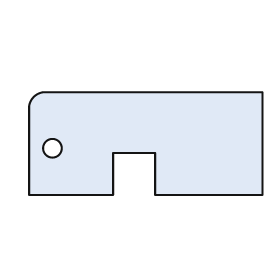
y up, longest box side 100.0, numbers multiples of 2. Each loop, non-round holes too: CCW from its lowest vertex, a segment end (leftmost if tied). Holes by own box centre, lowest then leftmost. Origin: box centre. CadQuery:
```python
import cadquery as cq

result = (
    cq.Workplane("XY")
    .moveTo(-50.0, -22.0)
    .lineTo(-14.0, -22.0)
    .lineTo(-14.0, -4.0)
    .lineTo(4.0, -4.0)
    .lineTo(4.0, -22.0)
    .lineTo(50.0, -22.0)
    .lineTo(50.0, 22.0)
    .lineTo(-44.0, 22.0)
    .threePointArc((-48.0, 20.0), (-50.0, 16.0))
    .close()
    .moveTo(-40.0, -2.0)
    .circle(4.0)
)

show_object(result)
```